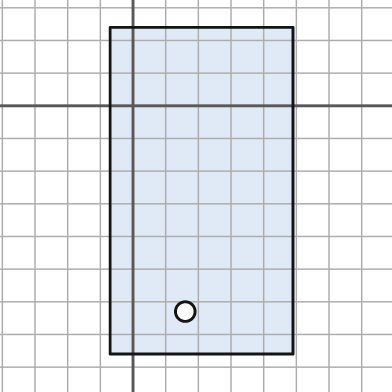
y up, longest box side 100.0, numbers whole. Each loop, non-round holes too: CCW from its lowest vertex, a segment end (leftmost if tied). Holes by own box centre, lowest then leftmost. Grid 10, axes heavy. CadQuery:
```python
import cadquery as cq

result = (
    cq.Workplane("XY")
    .moveTo(-7.0, -76.0)
    .lineTo(49.0, -76.0)
    .lineTo(49.0, 24.0)
    .lineTo(-7.0, 24.0)
    .close()
    .moveTo(16.0, -63.0)
    .circle(3.0)
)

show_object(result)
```